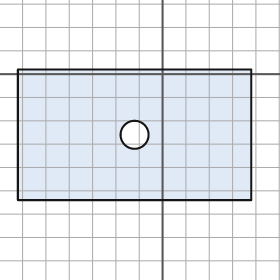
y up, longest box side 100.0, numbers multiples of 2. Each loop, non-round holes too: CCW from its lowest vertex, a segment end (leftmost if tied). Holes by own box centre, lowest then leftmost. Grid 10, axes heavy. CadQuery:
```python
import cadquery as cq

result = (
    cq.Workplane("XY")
    .moveTo(-62.0, -54.0)
    .lineTo(38.0, -54.0)
    .lineTo(38.0, 2.0)
    .lineTo(-62.0, 2.0)
    .close()
    .moveTo(-12.0, -26.0)
    .circle(6.0)
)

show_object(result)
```